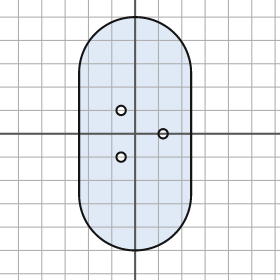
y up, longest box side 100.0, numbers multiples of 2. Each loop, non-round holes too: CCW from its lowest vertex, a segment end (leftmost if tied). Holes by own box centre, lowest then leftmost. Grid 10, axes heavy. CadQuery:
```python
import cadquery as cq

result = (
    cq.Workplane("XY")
    .moveTo(-24.0, -26.0)
    .threePointArc((0.0, -50.0), (24.0, -26.0))
    .lineTo(24.0, 26.0)
    .threePointArc((0.0, 50.0), (-24.0, 26.0))
    .close()
    .moveTo(-6.0, -10.0)
    .circle(2.0)
    .moveTo(12.0, 0.0)
    .circle(2.0)
    .moveTo(-6.0, 10.0)
    .circle(2.0)
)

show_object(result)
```